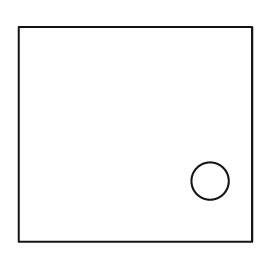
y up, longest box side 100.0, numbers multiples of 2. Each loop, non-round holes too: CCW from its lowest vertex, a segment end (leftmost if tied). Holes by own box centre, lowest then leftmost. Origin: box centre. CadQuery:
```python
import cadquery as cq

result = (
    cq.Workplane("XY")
    .moveTo(-50.0, -46.0)
    .lineTo(50.0, -46.0)
    .lineTo(50.0, 46.0)
    .lineTo(-50.0, 46.0)
    .close()
    .moveTo(32.0, -20.0)
    .circle(8.0)
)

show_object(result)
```